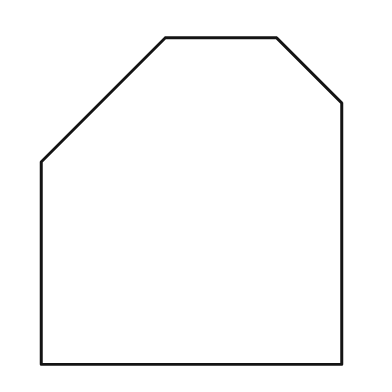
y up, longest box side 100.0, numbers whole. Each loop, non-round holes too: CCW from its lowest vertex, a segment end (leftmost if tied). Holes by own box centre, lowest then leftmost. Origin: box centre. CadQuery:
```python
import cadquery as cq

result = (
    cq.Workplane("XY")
    .moveTo(-46.0, -50.0)
    .lineTo(46.0, -50.0)
    .lineTo(46.0, 30.0)
    .lineTo(26.0, 50.0)
    .lineTo(-8.0, 50.0)
    .lineTo(-46.0, 12.0)
    .close()
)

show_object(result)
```